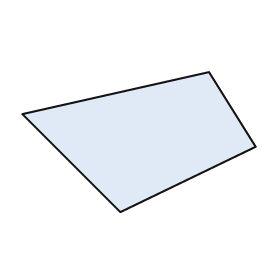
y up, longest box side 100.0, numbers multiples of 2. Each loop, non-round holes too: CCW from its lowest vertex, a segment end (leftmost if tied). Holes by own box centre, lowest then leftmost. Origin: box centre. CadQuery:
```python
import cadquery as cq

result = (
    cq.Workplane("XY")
    .moveTo(-8.0, -30.0)
    .lineTo(50.0, -2.0)
    .lineTo(30.0, 30.0)
    .lineTo(-50.0, 12.0)
    .close()
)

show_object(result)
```